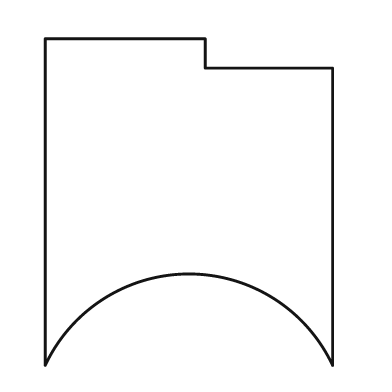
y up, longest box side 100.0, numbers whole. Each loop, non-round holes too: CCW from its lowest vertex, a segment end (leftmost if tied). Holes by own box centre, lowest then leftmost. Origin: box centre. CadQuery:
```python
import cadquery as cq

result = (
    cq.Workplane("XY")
    .moveTo(-44.0, -50.0)
    .threePointArc((0.0, -22.0), (44.0, -50.0))
    .lineTo(44.0, 41.0)
    .lineTo(5.0, 41.0)
    .lineTo(5.0, 50.0)
    .lineTo(-44.0, 50.0)
    .close()
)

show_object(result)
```